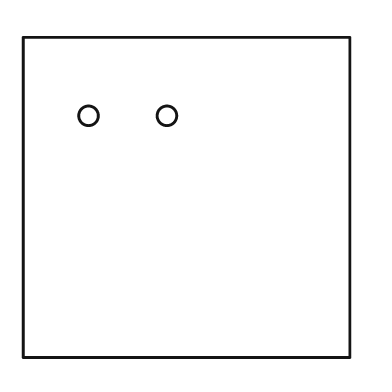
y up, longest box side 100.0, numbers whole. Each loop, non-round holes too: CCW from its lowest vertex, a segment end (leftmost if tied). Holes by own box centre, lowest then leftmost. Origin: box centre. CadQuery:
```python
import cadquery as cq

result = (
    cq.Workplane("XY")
    .moveTo(-50.0, -49.0)
    .lineTo(50.0, -49.0)
    .lineTo(50.0, 49.0)
    .lineTo(-50.0, 49.0)
    .close()
    .moveTo(-30.0, 25.0)
    .circle(3.0)
    .moveTo(-6.0, 25.0)
    .circle(3.0)
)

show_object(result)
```